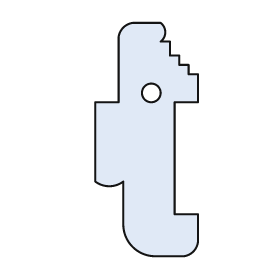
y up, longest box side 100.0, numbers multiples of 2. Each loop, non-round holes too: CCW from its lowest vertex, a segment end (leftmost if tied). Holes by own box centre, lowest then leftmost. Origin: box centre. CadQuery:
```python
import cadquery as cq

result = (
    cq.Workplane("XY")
    .moveTo(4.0, -50.0)
    .lineTo(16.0, -50.0)
    .threePointArc((20.0, -48.0), (22.0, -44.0))
    .lineTo(22.0, -32.0)
    .lineTo(12.0, -32.0)
    .lineTo(12.0, 16.0)
    .lineTo(22.0, 16.0)
    .lineTo(22.0, 28.0)
    .lineTo(18.0, 28.0)
    .lineTo(18.0, 32.0)
    .lineTo(14.0, 32.0)
    .lineTo(14.0, 36.0)
    .lineTo(10.0, 36.0)
    .lineTo(10.0, 42.0)
    .lineTo(6.0, 42.0)
    .threePointArc((8.0, 46.0), (6.0, 50.0))
    .lineTo(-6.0, 50.0)
    .threePointArc((-10.0, 48.0), (-12.0, 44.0))
    .lineTo(-12.0, 16.0)
    .lineTo(-22.0, 16.0)
    .lineTo(-22.0, -18.0)
    .threePointArc((-16.0, -20.0), (-10.0, -18.0))
    .lineTo(-10.0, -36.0)
    .threePointArc((-6.0, -46.0), (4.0, -50.0))
    .close()
    .moveTo(2.0, 20.0)
    .circle(4.0)
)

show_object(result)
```